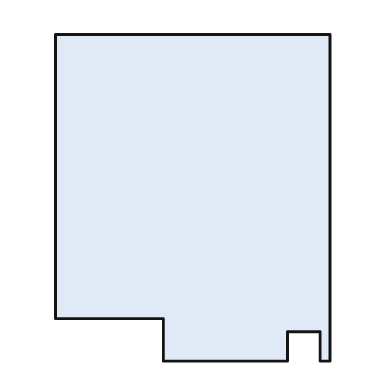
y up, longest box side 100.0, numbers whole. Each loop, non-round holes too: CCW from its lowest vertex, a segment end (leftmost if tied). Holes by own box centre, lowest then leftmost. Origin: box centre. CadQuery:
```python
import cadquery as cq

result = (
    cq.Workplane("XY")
    .moveTo(-9.0, -50.0)
    .lineTo(29.0, -50.0)
    .lineTo(29.0, -41.0)
    .lineTo(39.0, -41.0)
    .lineTo(39.0, -50.0)
    .lineTo(42.0, -50.0)
    .lineTo(42.0, 50.0)
    .lineTo(-42.0, 50.0)
    .lineTo(-42.0, -37.0)
    .lineTo(-9.0, -37.0)
    .close()
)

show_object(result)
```